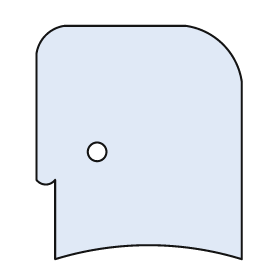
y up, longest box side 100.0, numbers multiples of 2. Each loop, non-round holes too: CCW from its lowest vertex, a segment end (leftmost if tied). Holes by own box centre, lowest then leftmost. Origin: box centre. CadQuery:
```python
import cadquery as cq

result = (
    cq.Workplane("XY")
    .moveTo(-36.0, -50.0)
    .threePointArc((4.0, -44.0), (44.0, -50.0))
    .lineTo(44.0, 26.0)
    .threePointArc((36.0, 42.0), (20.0, 50.0))
    .lineTo(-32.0, 50.0)
    .threePointArc((-40.0, 46.0), (-44.0, 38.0))
    .lineTo(-44.0, -16.0)
    .threePointArc((-40.0, -18.0), (-36.0, -16.0))
    .close()
    .moveTo(-18.0, -4.0)
    .circle(4.0)
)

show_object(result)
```